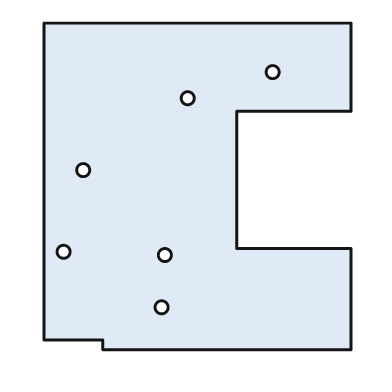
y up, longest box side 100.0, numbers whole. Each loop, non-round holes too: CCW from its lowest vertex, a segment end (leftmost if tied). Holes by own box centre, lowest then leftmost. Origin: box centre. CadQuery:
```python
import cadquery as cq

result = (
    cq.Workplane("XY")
    .moveTo(-29.0, -50.0)
    .lineTo(47.0, -50.0)
    .lineTo(47.0, -19.0)
    .lineTo(12.0, -19.0)
    .lineTo(12.0, 23.0)
    .lineTo(47.0, 23.0)
    .lineTo(47.0, 50.0)
    .lineTo(-47.0, 50.0)
    .lineTo(-47.0, -47.0)
    .lineTo(-29.0, -47.0)
    .close()
    .moveTo(-11.0, -37.0)
    .circle(2.0)
    .moveTo(-10.0, -21.0)
    .circle(2.0)
    .moveTo(-41.0, -20.0)
    .circle(2.0)
    .moveTo(-35.0, 5.0)
    .circle(2.0)
    .moveTo(-3.0, 27.0)
    .circle(2.0)
    .moveTo(23.0, 35.0)
    .circle(2.0)
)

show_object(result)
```